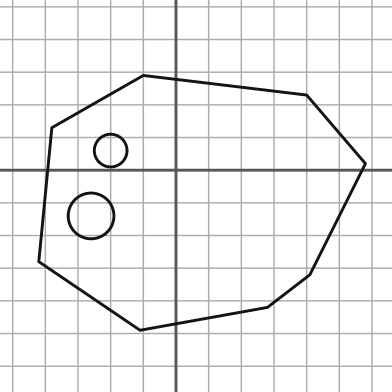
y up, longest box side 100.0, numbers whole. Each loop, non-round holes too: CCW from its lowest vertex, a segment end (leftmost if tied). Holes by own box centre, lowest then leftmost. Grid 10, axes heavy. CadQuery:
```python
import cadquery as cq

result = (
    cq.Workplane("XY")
    .moveTo(-11.0, -49.0)
    .lineTo(28.0, -42.0)
    .lineTo(41.0, -32.0)
    .lineTo(58.0, 2.0)
    .lineTo(40.0, 23.0)
    .lineTo(-10.0, 29.0)
    .lineTo(-38.0, 13.0)
    .lineTo(-42.0, -28.0)
    .close()
    .moveTo(-26.0, -14.0)
    .circle(7.0)
    .moveTo(-20.0, 6.0)
    .circle(5.0)
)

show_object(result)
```